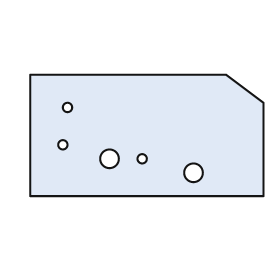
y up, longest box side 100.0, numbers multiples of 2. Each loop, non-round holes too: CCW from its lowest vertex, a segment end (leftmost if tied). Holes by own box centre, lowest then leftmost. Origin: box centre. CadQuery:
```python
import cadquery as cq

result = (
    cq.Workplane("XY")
    .moveTo(-50.0, -26.0)
    .lineTo(50.0, -26.0)
    .lineTo(50.0, 14.0)
    .lineTo(34.0, 26.0)
    .lineTo(-50.0, 26.0)
    .close()
    .moveTo(20.0, -16.0)
    .circle(4.0)
    .moveTo(-16.0, -10.0)
    .circle(4.0)
    .moveTo(-2.0, -10.0)
    .circle(2.0)
    .moveTo(-36.0, -4.0)
    .circle(2.0)
    .moveTo(-34.0, 12.0)
    .circle(2.0)
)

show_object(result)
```